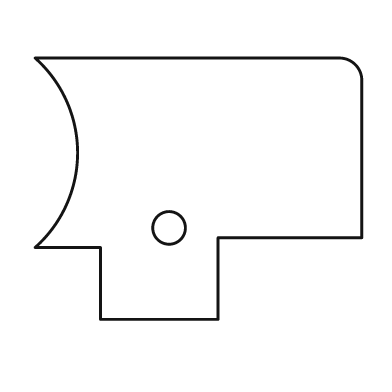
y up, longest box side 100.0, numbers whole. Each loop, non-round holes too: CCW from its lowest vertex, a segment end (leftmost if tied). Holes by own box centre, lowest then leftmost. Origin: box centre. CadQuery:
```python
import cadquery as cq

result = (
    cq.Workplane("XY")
    .moveTo(-30.0, -40.0)
    .lineTo(6.0, -40.0)
    .lineTo(6.0, -15.0)
    .lineTo(50.0, -15.0)
    .lineTo(50.0, 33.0)
    .threePointArc((48.0, 38.0), (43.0, 40.0))
    .lineTo(-50.0, 40.0)
    .threePointArc((-37.0, 11.0), (-50.0, -18.0))
    .lineTo(-30.0, -18.0)
    .close()
    .moveTo(-9.0, -12.0)
    .circle(5.0)
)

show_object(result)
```